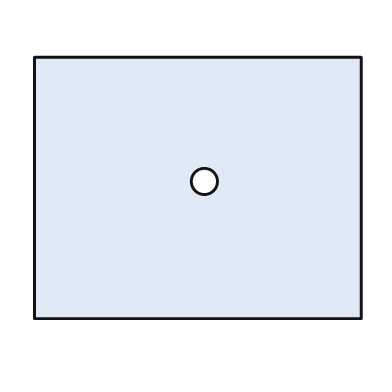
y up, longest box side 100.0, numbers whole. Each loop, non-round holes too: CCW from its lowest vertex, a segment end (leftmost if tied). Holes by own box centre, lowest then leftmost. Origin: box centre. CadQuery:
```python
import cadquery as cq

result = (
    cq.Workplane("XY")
    .moveTo(-50.0, -40.0)
    .lineTo(50.0, -40.0)
    .lineTo(50.0, 40.0)
    .lineTo(-50.0, 40.0)
    .close()
    .moveTo(2.0, 2.0)
    .circle(4.0)
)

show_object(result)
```